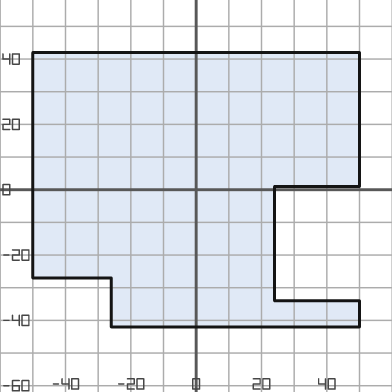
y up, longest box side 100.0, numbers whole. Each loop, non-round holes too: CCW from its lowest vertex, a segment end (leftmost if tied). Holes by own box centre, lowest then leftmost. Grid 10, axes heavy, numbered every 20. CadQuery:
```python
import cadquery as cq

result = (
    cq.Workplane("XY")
    .moveTo(-26.0, -42.0)
    .lineTo(50.0, -42.0)
    .lineTo(50.0, -34.0)
    .lineTo(24.0, -34.0)
    .lineTo(24.0, 1.0)
    .lineTo(50.0, 1.0)
    .lineTo(50.0, 42.0)
    .lineTo(-50.0, 42.0)
    .lineTo(-50.0, -27.0)
    .lineTo(-26.0, -27.0)
    .close()
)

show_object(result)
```